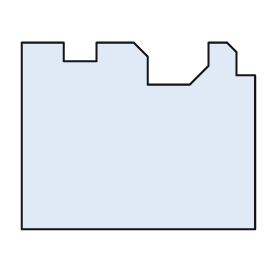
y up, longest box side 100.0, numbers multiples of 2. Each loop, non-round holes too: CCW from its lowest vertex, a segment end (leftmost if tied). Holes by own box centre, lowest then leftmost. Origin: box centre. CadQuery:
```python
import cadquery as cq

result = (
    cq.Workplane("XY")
    .moveTo(-50.0, -40.0)
    .lineTo(50.0, -40.0)
    .lineTo(50.0, 26.0)
    .lineTo(42.0, 26.0)
    .lineTo(42.0, 36.0)
    .lineTo(38.0, 40.0)
    .lineTo(30.0, 40.0)
    .lineTo(30.0, 30.0)
    .lineTo(22.0, 22.0)
    .lineTo(4.0, 22.0)
    .lineTo(4.0, 34.0)
    .lineTo(-2.0, 40.0)
    .lineTo(-18.0, 40.0)
    .lineTo(-18.0, 32.0)
    .lineTo(-32.0, 32.0)
    .lineTo(-32.0, 40.0)
    .lineTo(-50.0, 40.0)
    .close()
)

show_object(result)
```